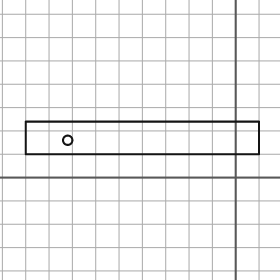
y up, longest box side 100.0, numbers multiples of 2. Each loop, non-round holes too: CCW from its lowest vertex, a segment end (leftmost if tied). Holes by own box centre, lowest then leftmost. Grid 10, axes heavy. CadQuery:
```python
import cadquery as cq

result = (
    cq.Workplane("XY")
    .moveTo(-90.0, 10.0)
    .lineTo(10.0, 10.0)
    .lineTo(10.0, 24.0)
    .lineTo(-90.0, 24.0)
    .close()
    .moveTo(-72.0, 16.0)
    .circle(2.0)
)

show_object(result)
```